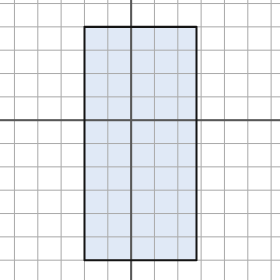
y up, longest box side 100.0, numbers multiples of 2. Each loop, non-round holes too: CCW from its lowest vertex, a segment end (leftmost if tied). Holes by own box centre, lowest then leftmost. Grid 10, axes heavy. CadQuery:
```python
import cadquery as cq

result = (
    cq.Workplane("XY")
    .moveTo(-20.0, -60.0)
    .lineTo(28.0, -60.0)
    .lineTo(28.0, 40.0)
    .lineTo(-20.0, 40.0)
    .close()
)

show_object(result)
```